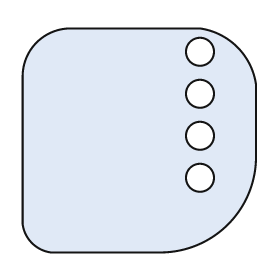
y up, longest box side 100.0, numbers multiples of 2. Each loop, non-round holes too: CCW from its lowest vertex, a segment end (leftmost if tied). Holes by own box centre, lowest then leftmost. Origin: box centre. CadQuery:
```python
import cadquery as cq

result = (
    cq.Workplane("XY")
    .moveTo(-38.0, -48.0)
    .lineTo(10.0, -48.0)
    .threePointArc((38.0, -36.0), (50.0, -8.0))
    .lineTo(50.0, 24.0)
    .threePointArc((42.0, 40.0), (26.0, 48.0))
    .lineTo(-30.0, 48.0)
    .threePointArc((-44.0, 42.0), (-50.0, 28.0))
    .lineTo(-50.0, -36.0)
    .threePointArc((-46.0, -44.0), (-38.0, -48.0))
    .close()
    .moveTo(26.0, -16.0)
    .circle(6.0)
    .moveTo(26.0, 2.0)
    .circle(6.0)
    .moveTo(26.0, 20.0)
    .circle(6.0)
    .moveTo(26.0, 38.0)
    .circle(6.0)
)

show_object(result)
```